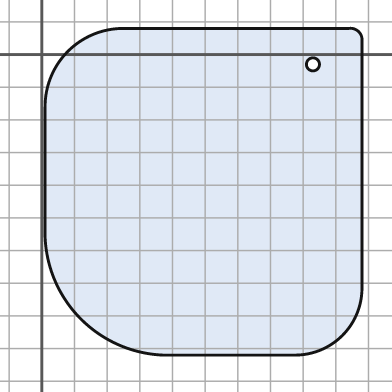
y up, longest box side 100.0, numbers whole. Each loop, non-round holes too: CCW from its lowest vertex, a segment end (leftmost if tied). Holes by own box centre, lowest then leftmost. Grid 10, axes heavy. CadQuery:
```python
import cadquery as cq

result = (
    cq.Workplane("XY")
    .moveTo(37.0, -92.0)
    .lineTo(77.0, -92.0)
    .threePointArc((92.0, -86.0), (98.0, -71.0))
    .lineTo(98.0, 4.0)
    .threePointArc((97.0, 7.0), (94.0, 8.0))
    .lineTo(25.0, 8.0)
    .threePointArc((8.0, 1.0), (1.0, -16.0))
    .lineTo(1.0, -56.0)
    .threePointArc((12.0, -81.0), (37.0, -92.0))
    .close()
    .moveTo(83.0, -3.0)
    .circle(2.0)
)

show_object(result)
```